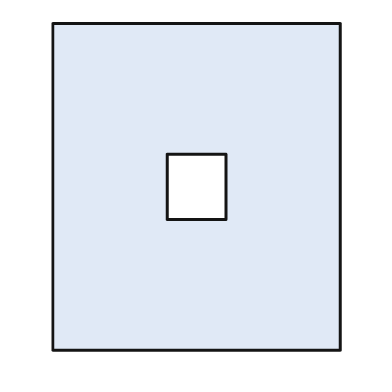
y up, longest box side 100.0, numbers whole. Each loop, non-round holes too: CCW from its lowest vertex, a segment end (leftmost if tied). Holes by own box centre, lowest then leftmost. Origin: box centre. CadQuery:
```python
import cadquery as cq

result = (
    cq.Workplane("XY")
    .moveTo(-44.0, -50.0)
    .lineTo(44.0, -50.0)
    .lineTo(44.0, 50.0)
    .lineTo(-44.0, 50.0)
    .close()
    .moveTo(-9.0, -10.0)
    .lineTo(9.0, -10.0)
    .lineTo(9.0, 10.0)
    .lineTo(-9.0, 10.0)
    .close()
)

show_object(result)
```